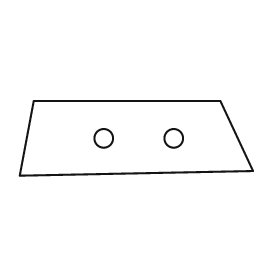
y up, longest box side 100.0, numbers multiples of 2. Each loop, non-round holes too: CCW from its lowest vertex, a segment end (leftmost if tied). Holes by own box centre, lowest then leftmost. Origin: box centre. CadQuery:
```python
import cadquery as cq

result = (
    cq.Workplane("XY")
    .moveTo(-50.0, -16.0)
    .lineTo(50.0, -14.0)
    .lineTo(36.0, 16.0)
    .lineTo(-44.0, 16.0)
    .close()
    .moveTo(-14.0, 0.0)
    .circle(4.0)
    .moveTo(16.0, 0.0)
    .circle(4.0)
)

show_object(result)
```